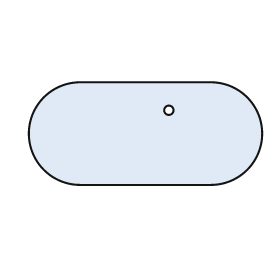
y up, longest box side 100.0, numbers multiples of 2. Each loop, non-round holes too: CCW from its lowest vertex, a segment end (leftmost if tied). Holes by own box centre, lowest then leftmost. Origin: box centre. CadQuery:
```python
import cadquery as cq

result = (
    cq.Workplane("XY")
    .moveTo(-28.0, -22.0)
    .lineTo(28.0, -22.0)
    .threePointArc((50.0, 0.0), (28.0, 22.0))
    .lineTo(-28.0, 22.0)
    .threePointArc((-50.0, 0.0), (-28.0, -22.0))
    .close()
    .moveTo(10.0, 10.0)
    .circle(2.0)
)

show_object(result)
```